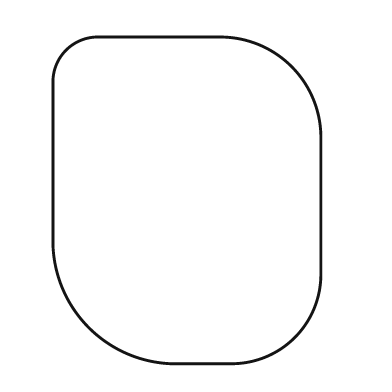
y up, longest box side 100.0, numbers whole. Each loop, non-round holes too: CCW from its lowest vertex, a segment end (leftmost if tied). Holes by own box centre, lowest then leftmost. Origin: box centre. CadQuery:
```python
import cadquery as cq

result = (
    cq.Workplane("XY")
    .moveTo(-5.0, -50.0)
    .lineTo(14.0, -50.0)
    .threePointArc((33.0, -42.0), (41.0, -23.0))
    .lineTo(41.0, 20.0)
    .threePointArc((32.0, 41.0), (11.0, 50.0))
    .lineTo(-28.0, 50.0)
    .threePointArc((-37.0, 46.0), (-41.0, 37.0))
    .lineTo(-41.0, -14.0)
    .threePointArc((-30.0, -39.0), (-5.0, -50.0))
    .close()
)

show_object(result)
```